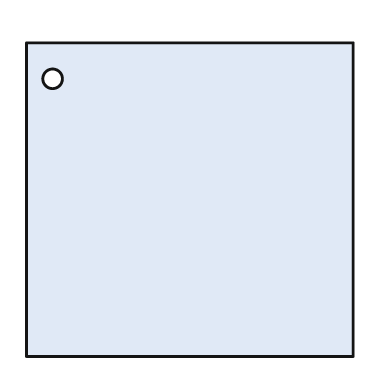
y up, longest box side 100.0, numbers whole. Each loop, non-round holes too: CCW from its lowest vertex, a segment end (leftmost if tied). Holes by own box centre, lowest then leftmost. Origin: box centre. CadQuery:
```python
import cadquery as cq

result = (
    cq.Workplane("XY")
    .moveTo(-50.0, -48.0)
    .lineTo(50.0, -48.0)
    .lineTo(50.0, 48.0)
    .lineTo(-50.0, 48.0)
    .close()
    .moveTo(-42.0, 37.0)
    .circle(3.0)
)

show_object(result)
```